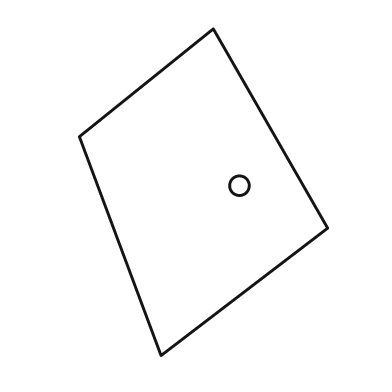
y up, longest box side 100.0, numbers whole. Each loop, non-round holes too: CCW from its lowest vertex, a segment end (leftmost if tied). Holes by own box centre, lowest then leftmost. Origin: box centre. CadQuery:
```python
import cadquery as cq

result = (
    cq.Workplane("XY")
    .moveTo(-13.0, -50.0)
    .lineTo(38.0, -11.0)
    .lineTo(3.0, 50.0)
    .lineTo(-38.0, 17.0)
    .close()
    .moveTo(11.0, 2.0)
    .circle(3.0)
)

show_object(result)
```